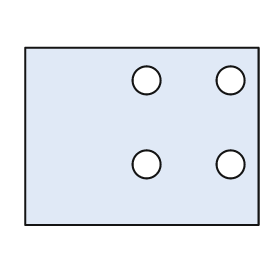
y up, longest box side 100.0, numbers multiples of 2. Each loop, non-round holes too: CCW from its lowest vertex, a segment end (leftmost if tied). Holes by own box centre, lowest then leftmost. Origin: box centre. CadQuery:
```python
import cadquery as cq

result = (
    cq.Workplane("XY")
    .moveTo(-50.0, -38.0)
    .lineTo(50.0, -38.0)
    .lineTo(50.0, 38.0)
    .lineTo(-50.0, 38.0)
    .close()
    .moveTo(2.0, -12.0)
    .circle(6.0)
    .moveTo(38.0, -12.0)
    .circle(6.0)
    .moveTo(2.0, 24.0)
    .circle(6.0)
    .moveTo(38.0, 24.0)
    .circle(6.0)
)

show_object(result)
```